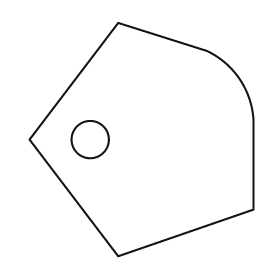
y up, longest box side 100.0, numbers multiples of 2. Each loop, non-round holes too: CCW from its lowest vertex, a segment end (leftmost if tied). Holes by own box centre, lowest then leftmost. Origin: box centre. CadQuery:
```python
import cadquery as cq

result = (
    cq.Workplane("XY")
    .moveTo(-10.0, -50.0)
    .lineTo(48.0, -30.0)
    .lineTo(48.0, 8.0)
    .threePointArc((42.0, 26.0), (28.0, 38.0))
    .lineTo(-10.0, 50.0)
    .lineTo(-48.0, 0.0)
    .close()
    .moveTo(-22.0, 0.0)
    .circle(8.0)
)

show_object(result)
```